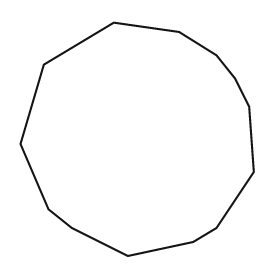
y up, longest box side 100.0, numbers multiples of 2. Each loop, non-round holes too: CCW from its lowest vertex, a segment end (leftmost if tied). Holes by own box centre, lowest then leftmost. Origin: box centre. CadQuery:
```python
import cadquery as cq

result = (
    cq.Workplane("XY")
    .moveTo(-4.0, -50.0)
    .lineTo(24.0, -44.0)
    .lineTo(34.0, -38.0)
    .lineTo(50.0, -14.0)
    .lineTo(48.0, 14.0)
    .lineTo(42.0, 26.0)
    .lineTo(34.0, 36.0)
    .lineTo(18.0, 46.0)
    .lineTo(-10.0, 50.0)
    .lineTo(-40.0, 32.0)
    .lineTo(-50.0, -2.0)
    .lineTo(-38.0, -30.0)
    .lineTo(-28.0, -38.0)
    .close()
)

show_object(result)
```